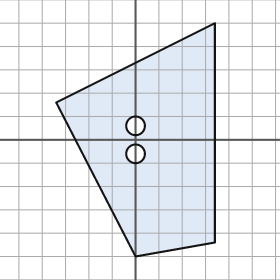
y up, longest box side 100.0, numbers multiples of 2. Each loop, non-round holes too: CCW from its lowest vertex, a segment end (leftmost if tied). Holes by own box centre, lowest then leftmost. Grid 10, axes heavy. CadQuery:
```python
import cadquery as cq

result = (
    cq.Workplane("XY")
    .moveTo(0.0, -50.0)
    .lineTo(34.0, -44.0)
    .lineTo(34.0, 50.0)
    .lineTo(-34.0, 16.0)
    .close()
    .moveTo(0.0, -6.0)
    .circle(4.0)
    .moveTo(0.0, 6.0)
    .circle(4.0)
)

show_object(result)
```